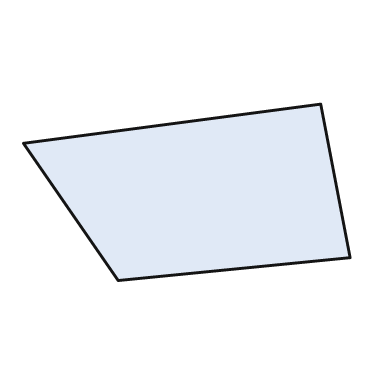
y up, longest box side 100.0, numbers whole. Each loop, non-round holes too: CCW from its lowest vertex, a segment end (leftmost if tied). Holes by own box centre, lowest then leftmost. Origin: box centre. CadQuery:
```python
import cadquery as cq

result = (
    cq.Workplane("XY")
    .moveTo(-21.0, -27.0)
    .lineTo(50.0, -20.0)
    .lineTo(41.0, 27.0)
    .lineTo(-50.0, 15.0)
    .close()
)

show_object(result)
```